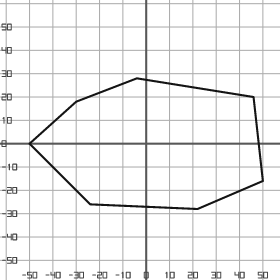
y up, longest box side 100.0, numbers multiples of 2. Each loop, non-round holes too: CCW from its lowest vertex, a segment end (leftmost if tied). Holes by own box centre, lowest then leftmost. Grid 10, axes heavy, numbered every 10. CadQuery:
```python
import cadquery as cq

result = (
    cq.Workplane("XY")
    .moveTo(22.0, -28.0)
    .lineTo(50.0, -16.0)
    .lineTo(46.0, 20.0)
    .lineTo(-4.0, 28.0)
    .lineTo(-30.0, 18.0)
    .lineTo(-50.0, 0.0)
    .lineTo(-24.0, -26.0)
    .close()
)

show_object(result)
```